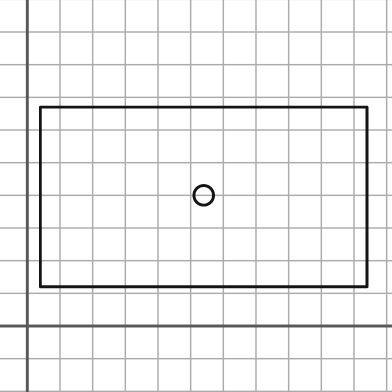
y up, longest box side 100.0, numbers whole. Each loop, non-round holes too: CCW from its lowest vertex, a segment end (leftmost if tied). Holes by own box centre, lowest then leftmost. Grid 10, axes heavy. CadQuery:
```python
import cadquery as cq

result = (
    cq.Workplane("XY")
    .moveTo(4.0, 12.0)
    .lineTo(104.0, 12.0)
    .lineTo(104.0, 67.0)
    .lineTo(4.0, 67.0)
    .close()
    .moveTo(54.0, 40.0)
    .circle(3.0)
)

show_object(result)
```